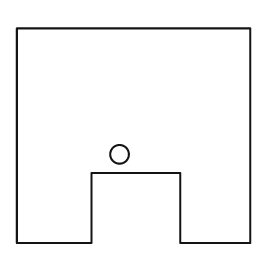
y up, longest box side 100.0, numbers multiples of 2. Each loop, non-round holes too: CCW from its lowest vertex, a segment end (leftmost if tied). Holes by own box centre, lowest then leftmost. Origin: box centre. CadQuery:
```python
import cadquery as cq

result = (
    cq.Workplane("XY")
    .moveTo(-50.0, -46.0)
    .lineTo(-18.0, -46.0)
    .lineTo(-18.0, -16.0)
    .lineTo(20.0, -16.0)
    .lineTo(20.0, -46.0)
    .lineTo(50.0, -46.0)
    .lineTo(50.0, 46.0)
    .lineTo(-50.0, 46.0)
    .close()
    .moveTo(-6.0, -8.0)
    .circle(4.0)
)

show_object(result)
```